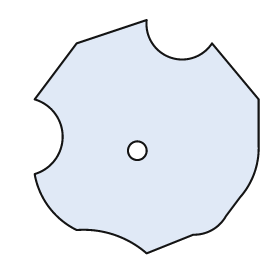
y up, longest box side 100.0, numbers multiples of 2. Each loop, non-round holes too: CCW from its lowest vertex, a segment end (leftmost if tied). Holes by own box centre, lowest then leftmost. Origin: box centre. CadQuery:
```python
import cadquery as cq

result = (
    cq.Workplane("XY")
    .moveTo(0.0, -50.0)
    .lineTo(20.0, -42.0)
    .threePointArc((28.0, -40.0), (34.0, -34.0))
    .lineTo(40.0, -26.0)
    .threePointArc((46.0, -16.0), (48.0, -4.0))
    .lineTo(48.0, 16.0)
    .lineTo(28.0, 40.0)
    .threePointArc((10.0, 34.0), (0.0, 50.0))
    .lineTo(-30.0, 40.0)
    .lineTo(-48.0, 16.0)
    .threePointArc((-36.0, 0.0), (-48.0, -16.0))
    .threePointArc((-42.0, -30.0), (-30.0, -40.0))
    .threePointArc((-14.0, -42.0), (0.0, -50.0))
    .close()
    .moveTo(-4.0, -6.0)
    .circle(4.0)
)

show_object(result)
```